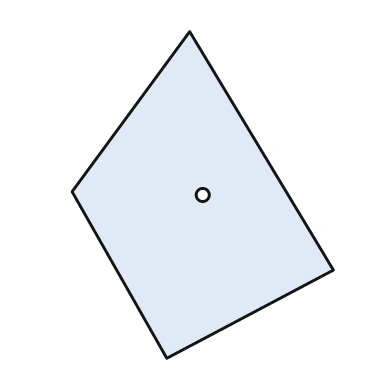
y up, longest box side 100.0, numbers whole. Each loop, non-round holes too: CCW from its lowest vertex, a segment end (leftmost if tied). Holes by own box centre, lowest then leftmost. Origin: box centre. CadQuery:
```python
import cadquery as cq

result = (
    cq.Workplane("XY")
    .moveTo(-11.0, -50.0)
    .lineTo(40.0, -23.0)
    .lineTo(-4.0, 50.0)
    .lineTo(-40.0, 1.0)
    .close()
    .moveTo(0.0, 0.0)
    .circle(2.0)
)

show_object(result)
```